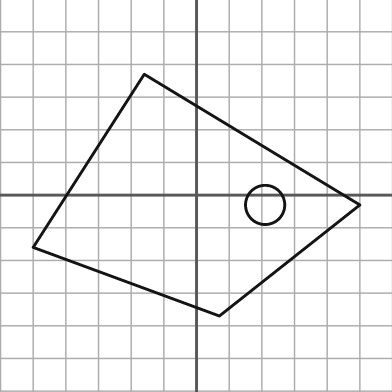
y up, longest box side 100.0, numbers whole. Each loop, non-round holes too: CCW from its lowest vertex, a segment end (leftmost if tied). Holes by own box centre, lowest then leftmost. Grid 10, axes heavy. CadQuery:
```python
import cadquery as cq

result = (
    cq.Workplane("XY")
    .moveTo(7.0, -37.0)
    .lineTo(50.0, -3.0)
    .lineTo(-16.0, 37.0)
    .lineTo(-50.0, -16.0)
    .close()
    .moveTo(21.0, -3.0)
    .circle(6.0)
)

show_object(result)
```